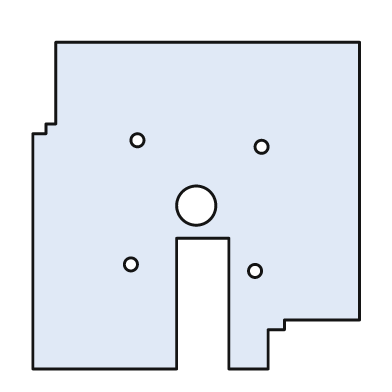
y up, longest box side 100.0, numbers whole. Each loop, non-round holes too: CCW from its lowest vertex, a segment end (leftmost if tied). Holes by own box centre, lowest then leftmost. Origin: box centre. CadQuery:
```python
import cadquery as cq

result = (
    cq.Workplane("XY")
    .moveTo(-50.0, -50.0)
    .lineTo(-6.0, -50.0)
    .lineTo(-6.0, -10.0)
    .lineTo(10.0, -10.0)
    .lineTo(10.0, -50.0)
    .lineTo(22.0, -50.0)
    .lineTo(22.0, -38.0)
    .lineTo(27.0, -38.0)
    .lineTo(27.0, -35.0)
    .lineTo(50.0, -35.0)
    .lineTo(50.0, 50.0)
    .lineTo(-43.0, 50.0)
    .lineTo(-43.0, 25.0)
    .lineTo(-46.0, 25.0)
    .lineTo(-46.0, 22.0)
    .lineTo(-50.0, 22.0)
    .close()
    .moveTo(18.0, -20.0)
    .circle(2.0)
    .moveTo(-20.0, -18.0)
    .circle(2.0)
    .moveTo(0.0, 0.0)
    .circle(6.0)
    .moveTo(20.0, 18.0)
    .circle(2.0)
    .moveTo(-18.0, 20.0)
    .circle(2.0)
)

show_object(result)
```